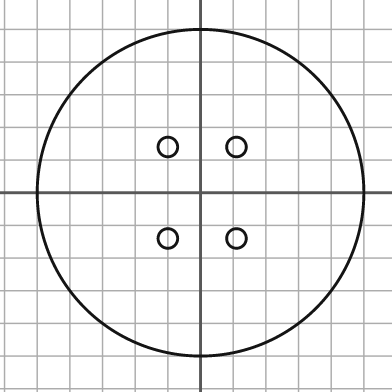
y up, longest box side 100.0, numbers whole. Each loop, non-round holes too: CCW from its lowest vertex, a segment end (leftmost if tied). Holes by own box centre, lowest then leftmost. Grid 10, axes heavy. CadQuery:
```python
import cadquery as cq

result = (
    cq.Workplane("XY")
    .moveTo(0.0, 0.0)
    .circle(50.0)
    .moveTo(-10.0, -14.0)
    .circle(3.0)
    .moveTo(11.0, -14.0)
    .circle(3.0)
    .moveTo(-10.0, 14.0)
    .circle(3.0)
    .moveTo(11.0, 14.0)
    .circle(3.0)
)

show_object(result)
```